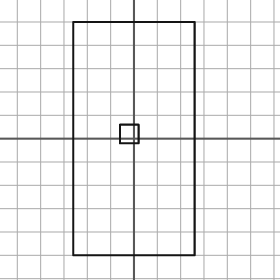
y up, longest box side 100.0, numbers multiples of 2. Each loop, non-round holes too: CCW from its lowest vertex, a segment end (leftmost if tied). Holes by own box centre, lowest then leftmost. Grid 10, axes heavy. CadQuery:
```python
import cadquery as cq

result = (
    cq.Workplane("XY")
    .moveTo(-26.0, -50.0)
    .lineTo(26.0, -50.0)
    .lineTo(26.0, 50.0)
    .lineTo(-26.0, 50.0)
    .close()
    .moveTo(-6.0, -2.0)
    .lineTo(2.0, -2.0)
    .lineTo(2.0, 6.0)
    .lineTo(-6.0, 6.0)
    .close()
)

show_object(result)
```